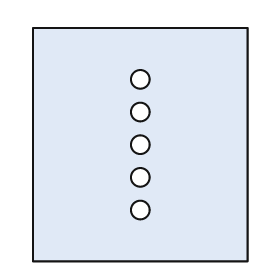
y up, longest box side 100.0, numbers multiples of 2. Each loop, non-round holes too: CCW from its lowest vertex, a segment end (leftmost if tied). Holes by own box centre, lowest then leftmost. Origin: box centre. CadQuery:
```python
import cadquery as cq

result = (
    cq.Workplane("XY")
    .moveTo(-46.0, -50.0)
    .lineTo(46.0, -50.0)
    .lineTo(46.0, 50.0)
    .lineTo(-46.0, 50.0)
    .close()
    .moveTo(0.0, -28.0)
    .circle(4.0)
    .moveTo(0.0, -14.0)
    .circle(4.0)
    .moveTo(0.0, 0.0)
    .circle(4.0)
    .moveTo(0.0, 14.0)
    .circle(4.0)
    .moveTo(0.0, 28.0)
    .circle(4.0)
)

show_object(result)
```